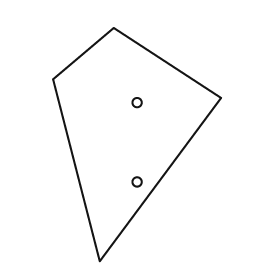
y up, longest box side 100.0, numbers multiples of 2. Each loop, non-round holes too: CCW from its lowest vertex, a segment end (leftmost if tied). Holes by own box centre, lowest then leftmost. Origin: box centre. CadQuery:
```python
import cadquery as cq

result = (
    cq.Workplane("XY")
    .moveTo(-16.0, -50.0)
    .lineTo(36.0, 20.0)
    .lineTo(-10.0, 50.0)
    .lineTo(-36.0, 28.0)
    .close()
    .moveTo(0.0, -16.0)
    .circle(2.0)
    .moveTo(0.0, 18.0)
    .circle(2.0)
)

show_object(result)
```